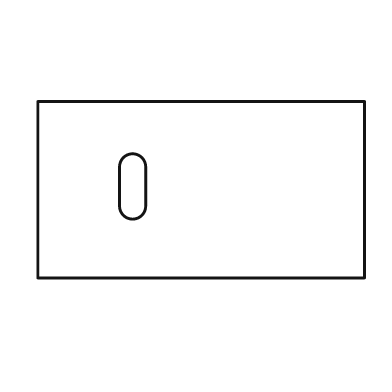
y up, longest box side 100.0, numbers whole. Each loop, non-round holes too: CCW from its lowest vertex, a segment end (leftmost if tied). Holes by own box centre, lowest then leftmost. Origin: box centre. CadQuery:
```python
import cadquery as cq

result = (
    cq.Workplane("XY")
    .moveTo(-50.0, -27.0)
    .lineTo(50.0, -27.0)
    .lineTo(50.0, 27.0)
    .lineTo(-50.0, 27.0)
    .close()
    .moveTo(-25.0, -5.0)
    .threePointArc((-21.0, -9.0), (-17.0, -5.0))
    .lineTo(-17.0, 7.0)
    .threePointArc((-21.0, 11.0), (-25.0, 7.0))
    .close()
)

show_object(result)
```